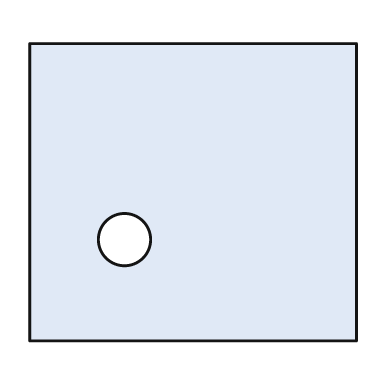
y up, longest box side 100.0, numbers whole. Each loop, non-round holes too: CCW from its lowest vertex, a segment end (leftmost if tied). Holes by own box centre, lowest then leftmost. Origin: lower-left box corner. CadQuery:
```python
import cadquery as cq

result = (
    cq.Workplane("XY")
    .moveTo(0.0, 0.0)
    .lineTo(100.0, 0.0)
    .lineTo(100.0, 91.0)
    .lineTo(0.0, 91.0)
    .close()
    .moveTo(29.0, 31.0)
    .circle(8.0)
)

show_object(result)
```